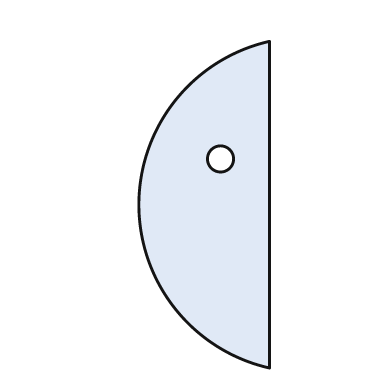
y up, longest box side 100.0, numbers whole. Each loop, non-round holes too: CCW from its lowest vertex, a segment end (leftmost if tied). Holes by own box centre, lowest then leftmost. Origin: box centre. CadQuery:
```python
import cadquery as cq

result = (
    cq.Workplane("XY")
    .moveTo(20.0, -50.0)
    .lineTo(20.0, 50.0)
    .threePointArc((-20.0, 0.0), (20.0, -50.0))
    .close()
    .moveTo(5.0, 14.0)
    .circle(4.0)
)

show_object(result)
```